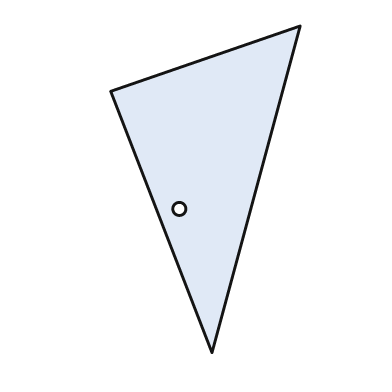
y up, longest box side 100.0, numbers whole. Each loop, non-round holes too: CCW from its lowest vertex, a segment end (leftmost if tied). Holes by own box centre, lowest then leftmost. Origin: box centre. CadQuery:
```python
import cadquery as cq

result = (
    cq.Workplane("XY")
    .moveTo(2.0, -50.0)
    .lineTo(29.0, 50.0)
    .lineTo(-29.0, 30.0)
    .close()
    .moveTo(-8.0, -6.0)
    .circle(2.0)
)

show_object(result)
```